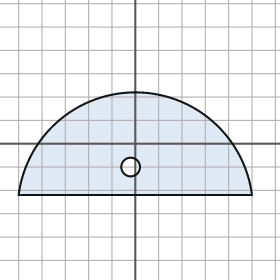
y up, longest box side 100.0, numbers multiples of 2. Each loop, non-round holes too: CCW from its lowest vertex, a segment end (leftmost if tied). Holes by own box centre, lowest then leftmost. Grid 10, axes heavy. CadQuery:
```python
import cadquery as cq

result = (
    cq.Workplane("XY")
    .moveTo(-50.0, -22.0)
    .lineTo(50.0, -22.0)
    .threePointArc((0.0, 22.0), (-50.0, -22.0))
    .close()
    .moveTo(-2.0, -10.0)
    .circle(4.0)
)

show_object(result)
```